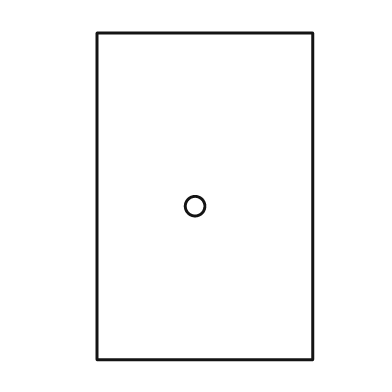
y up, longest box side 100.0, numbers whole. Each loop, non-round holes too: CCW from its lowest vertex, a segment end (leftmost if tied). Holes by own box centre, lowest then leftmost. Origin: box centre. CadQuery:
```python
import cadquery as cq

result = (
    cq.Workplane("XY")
    .moveTo(-33.0, -50.0)
    .lineTo(33.0, -50.0)
    .lineTo(33.0, 50.0)
    .lineTo(-33.0, 50.0)
    .close()
    .moveTo(-3.0, -3.0)
    .circle(3.0)
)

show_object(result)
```